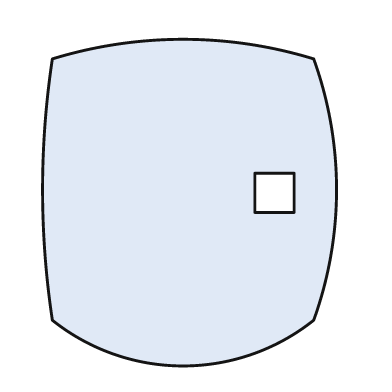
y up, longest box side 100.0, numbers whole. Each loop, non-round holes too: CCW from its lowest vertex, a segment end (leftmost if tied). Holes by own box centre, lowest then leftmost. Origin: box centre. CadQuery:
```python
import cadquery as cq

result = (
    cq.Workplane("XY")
    .moveTo(-42.0, -36.0)
    .threePointArc((-2.0, -50.0), (38.0, -36.0))
    .threePointArc((45.0, 4.0), (38.0, 44.0))
    .threePointArc((-2.0, 50.0), (-42.0, 44.0))
    .threePointArc((-45.0, 4.0), (-42.0, -36.0))
    .close()
    .moveTo(20.0, -3.0)
    .lineTo(32.0, -3.0)
    .lineTo(32.0, 9.0)
    .lineTo(20.0, 9.0)
    .close()
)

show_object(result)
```